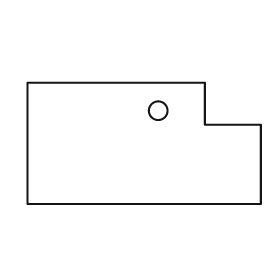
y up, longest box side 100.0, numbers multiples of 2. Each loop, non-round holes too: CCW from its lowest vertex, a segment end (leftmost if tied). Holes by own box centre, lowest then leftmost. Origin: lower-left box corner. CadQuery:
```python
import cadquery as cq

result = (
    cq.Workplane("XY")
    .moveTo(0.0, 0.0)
    .lineTo(100.0, 0.0)
    .lineTo(100.0, 34.0)
    .lineTo(76.0, 34.0)
    .lineTo(76.0, 52.0)
    .lineTo(0.0, 52.0)
    .close()
    .moveTo(56.0, 40.0)
    .circle(4.0)
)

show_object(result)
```